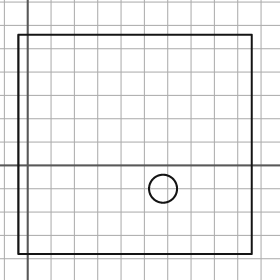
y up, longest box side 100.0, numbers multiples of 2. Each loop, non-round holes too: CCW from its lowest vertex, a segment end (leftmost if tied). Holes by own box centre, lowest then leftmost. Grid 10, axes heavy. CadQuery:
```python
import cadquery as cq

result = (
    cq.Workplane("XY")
    .moveTo(-4.0, -38.0)
    .lineTo(96.0, -38.0)
    .lineTo(96.0, 56.0)
    .lineTo(-4.0, 56.0)
    .close()
    .moveTo(58.0, -10.0)
    .circle(6.0)
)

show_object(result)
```